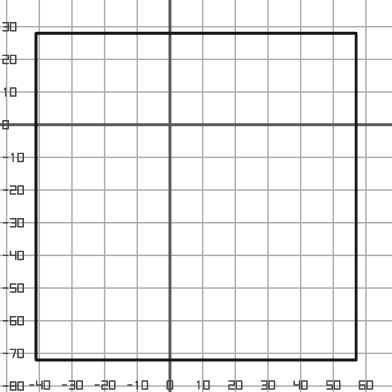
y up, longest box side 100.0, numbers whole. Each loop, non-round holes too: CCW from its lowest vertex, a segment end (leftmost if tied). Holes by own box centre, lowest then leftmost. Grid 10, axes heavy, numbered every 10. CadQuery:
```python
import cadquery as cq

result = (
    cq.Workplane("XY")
    .moveTo(-41.0, -72.0)
    .lineTo(57.0, -72.0)
    .lineTo(57.0, 28.0)
    .lineTo(-41.0, 28.0)
    .close()
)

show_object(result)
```